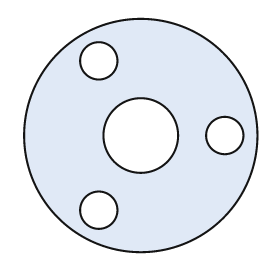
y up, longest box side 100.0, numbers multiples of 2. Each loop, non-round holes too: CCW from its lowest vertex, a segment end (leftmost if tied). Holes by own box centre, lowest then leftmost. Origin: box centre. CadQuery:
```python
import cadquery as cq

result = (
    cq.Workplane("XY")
    .moveTo(0.0, 0.0)
    .circle(50.0)
    .moveTo(-18.0, -32.0)
    .circle(8.0)
    .moveTo(0.0, 0.0)
    .circle(16.0)
    .moveTo(36.0, 0.0)
    .circle(8.0)
    .moveTo(-18.0, 32.0)
    .circle(8.0)
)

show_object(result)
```